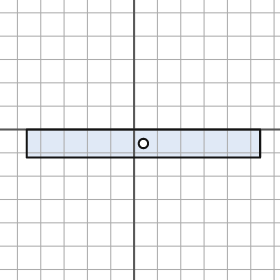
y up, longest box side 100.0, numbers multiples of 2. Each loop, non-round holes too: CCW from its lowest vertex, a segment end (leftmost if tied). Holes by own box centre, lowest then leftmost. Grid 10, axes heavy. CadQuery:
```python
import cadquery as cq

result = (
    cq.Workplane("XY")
    .moveTo(-46.0, -12.0)
    .lineTo(54.0, -12.0)
    .lineTo(54.0, 0.0)
    .lineTo(-46.0, 0.0)
    .close()
    .moveTo(4.0, -6.0)
    .circle(2.0)
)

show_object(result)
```